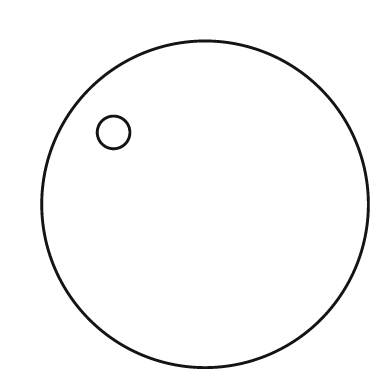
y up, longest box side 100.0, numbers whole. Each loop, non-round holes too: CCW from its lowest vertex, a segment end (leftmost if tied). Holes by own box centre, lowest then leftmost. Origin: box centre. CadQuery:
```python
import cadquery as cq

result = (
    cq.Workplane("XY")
    .moveTo(0.0, 0.0)
    .circle(50.0)
    .moveTo(-28.0, 22.0)
    .circle(5.0)
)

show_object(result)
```